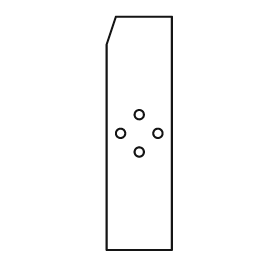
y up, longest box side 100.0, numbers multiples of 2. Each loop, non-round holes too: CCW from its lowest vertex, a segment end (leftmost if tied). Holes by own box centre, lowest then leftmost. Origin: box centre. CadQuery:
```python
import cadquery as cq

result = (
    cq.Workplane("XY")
    .moveTo(-14.0, -50.0)
    .lineTo(14.0, -50.0)
    .lineTo(14.0, 50.0)
    .lineTo(-10.0, 50.0)
    .lineTo(-14.0, 38.0)
    .close()
    .moveTo(0.0, -8.0)
    .circle(2.0)
    .moveTo(-8.0, 0.0)
    .circle(2.0)
    .moveTo(8.0, 0.0)
    .circle(2.0)
    .moveTo(0.0, 8.0)
    .circle(2.0)
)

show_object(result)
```